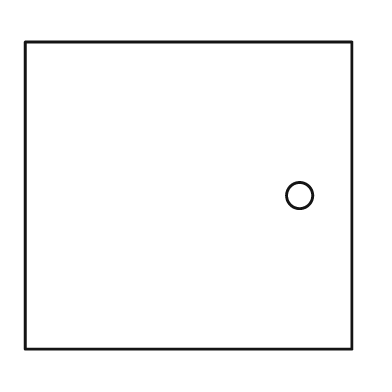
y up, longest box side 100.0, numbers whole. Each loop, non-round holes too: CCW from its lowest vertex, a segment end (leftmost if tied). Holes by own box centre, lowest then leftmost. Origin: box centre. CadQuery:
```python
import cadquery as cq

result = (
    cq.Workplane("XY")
    .moveTo(-50.0, -47.0)
    .lineTo(50.0, -47.0)
    .lineTo(50.0, 47.0)
    .lineTo(-50.0, 47.0)
    .close()
    .moveTo(34.0, 0.0)
    .circle(4.0)
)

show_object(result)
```